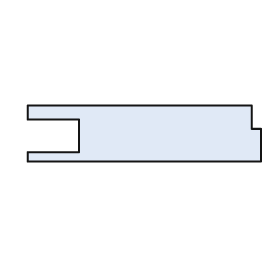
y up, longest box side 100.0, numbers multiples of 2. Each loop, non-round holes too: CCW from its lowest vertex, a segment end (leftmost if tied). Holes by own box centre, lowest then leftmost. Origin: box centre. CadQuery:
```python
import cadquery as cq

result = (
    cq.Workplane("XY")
    .moveTo(-50.0, -12.0)
    .lineTo(50.0, -12.0)
    .lineTo(50.0, 2.0)
    .lineTo(46.0, 2.0)
    .lineTo(46.0, 12.0)
    .lineTo(-50.0, 12.0)
    .lineTo(-50.0, 6.0)
    .lineTo(-28.0, 6.0)
    .lineTo(-28.0, -8.0)
    .lineTo(-50.0, -8.0)
    .close()
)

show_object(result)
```